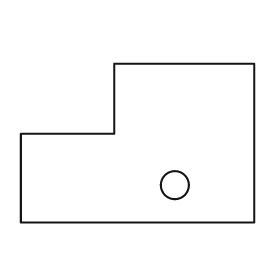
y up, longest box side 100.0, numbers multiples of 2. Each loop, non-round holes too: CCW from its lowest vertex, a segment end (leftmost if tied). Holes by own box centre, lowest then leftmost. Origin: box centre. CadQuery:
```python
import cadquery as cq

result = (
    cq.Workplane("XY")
    .moveTo(-50.0, -34.0)
    .lineTo(50.0, -34.0)
    .lineTo(50.0, 34.0)
    .lineTo(-10.0, 34.0)
    .lineTo(-10.0, 4.0)
    .lineTo(-50.0, 4.0)
    .close()
    .moveTo(16.0, -18.0)
    .circle(6.0)
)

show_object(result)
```